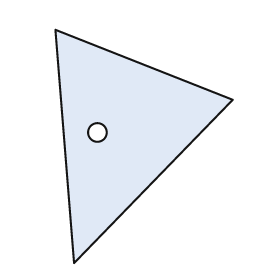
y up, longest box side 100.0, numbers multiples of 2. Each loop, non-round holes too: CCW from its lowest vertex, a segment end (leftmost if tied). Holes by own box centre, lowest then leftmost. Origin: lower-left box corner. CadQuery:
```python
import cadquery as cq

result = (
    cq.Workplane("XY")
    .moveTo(8.0, 0.0)
    .lineTo(76.0, 70.0)
    .lineTo(0.0, 100.0)
    .close()
    .moveTo(18.0, 56.0)
    .circle(4.0)
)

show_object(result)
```